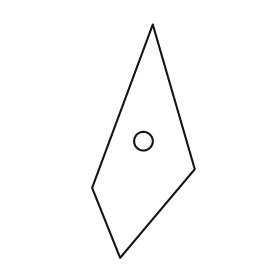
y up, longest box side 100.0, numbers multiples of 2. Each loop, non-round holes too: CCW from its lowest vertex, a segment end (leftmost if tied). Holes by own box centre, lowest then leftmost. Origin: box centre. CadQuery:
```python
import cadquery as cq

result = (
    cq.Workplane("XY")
    .moveTo(-10.0, -50.0)
    .lineTo(22.0, -12.0)
    .lineTo(4.0, 50.0)
    .lineTo(-22.0, -20.0)
    .close()
    .moveTo(0.0, 0.0)
    .circle(4.0)
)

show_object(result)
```